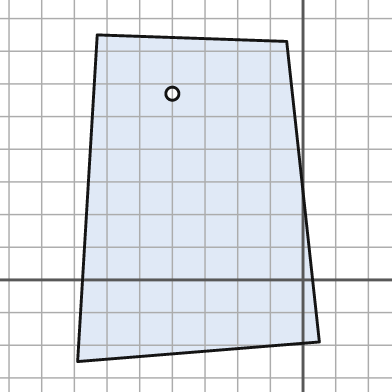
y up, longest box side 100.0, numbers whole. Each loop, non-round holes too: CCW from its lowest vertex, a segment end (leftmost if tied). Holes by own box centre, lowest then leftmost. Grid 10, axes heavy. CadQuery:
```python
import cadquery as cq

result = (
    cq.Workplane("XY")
    .moveTo(-69.0, -25.0)
    .lineTo(5.0, -19.0)
    .lineTo(-5.0, 73.0)
    .lineTo(-63.0, 75.0)
    .close()
    .moveTo(-40.0, 57.0)
    .circle(2.0)
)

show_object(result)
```